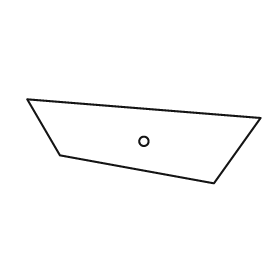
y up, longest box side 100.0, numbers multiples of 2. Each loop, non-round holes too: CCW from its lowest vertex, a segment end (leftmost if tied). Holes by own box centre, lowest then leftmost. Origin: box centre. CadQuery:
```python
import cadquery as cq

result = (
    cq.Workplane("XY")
    .moveTo(30.0, -18.0)
    .lineTo(50.0, 10.0)
    .lineTo(-50.0, 18.0)
    .lineTo(-36.0, -6.0)
    .close()
    .moveTo(0.0, 0.0)
    .circle(2.0)
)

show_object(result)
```